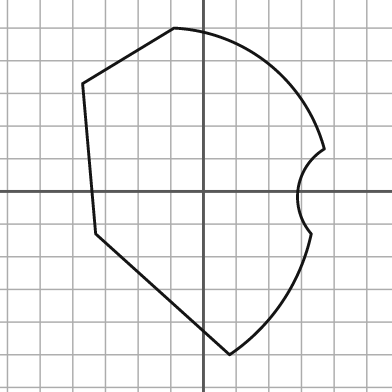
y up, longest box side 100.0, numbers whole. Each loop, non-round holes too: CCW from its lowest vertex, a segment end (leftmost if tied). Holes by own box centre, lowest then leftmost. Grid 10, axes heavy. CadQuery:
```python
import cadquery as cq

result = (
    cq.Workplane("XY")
    .moveTo(8.0, -50.0)
    .threePointArc((24.0, -34.0), (33.0, -13.0))
    .threePointArc((29.0, 1.0), (37.0, 13.0))
    .threePointArc((20.0, 39.0), (-9.0, 50.0))
    .lineTo(-37.0, 33.0)
    .lineTo(-33.0, -13.0)
    .close()
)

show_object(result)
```